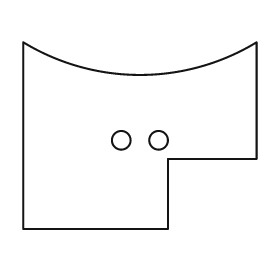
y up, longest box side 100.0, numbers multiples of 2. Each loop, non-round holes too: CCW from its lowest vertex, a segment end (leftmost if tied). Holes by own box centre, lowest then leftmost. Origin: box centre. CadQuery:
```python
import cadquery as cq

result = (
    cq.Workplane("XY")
    .moveTo(-50.0, -40.0)
    .lineTo(12.0, -40.0)
    .lineTo(12.0, -10.0)
    .lineTo(50.0, -10.0)
    .lineTo(50.0, 40.0)
    .threePointArc((0.0, 26.0), (-50.0, 40.0))
    .close()
    .moveTo(-8.0, -2.0)
    .circle(4.0)
    .moveTo(8.0, -2.0)
    .circle(4.0)
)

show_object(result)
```